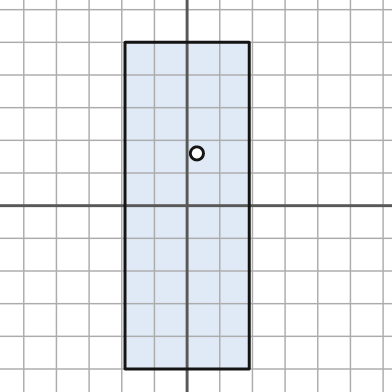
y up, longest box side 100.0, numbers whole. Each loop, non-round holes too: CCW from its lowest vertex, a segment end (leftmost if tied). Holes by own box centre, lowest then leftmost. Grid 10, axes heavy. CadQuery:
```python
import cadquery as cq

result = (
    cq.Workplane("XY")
    .moveTo(-19.0, -50.0)
    .lineTo(19.0, -50.0)
    .lineTo(19.0, 50.0)
    .lineTo(-19.0, 50.0)
    .close()
    .moveTo(3.0, 16.0)
    .circle(2.0)
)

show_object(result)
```